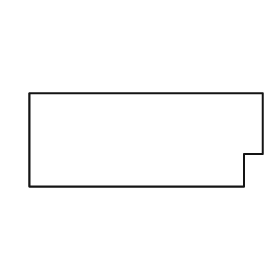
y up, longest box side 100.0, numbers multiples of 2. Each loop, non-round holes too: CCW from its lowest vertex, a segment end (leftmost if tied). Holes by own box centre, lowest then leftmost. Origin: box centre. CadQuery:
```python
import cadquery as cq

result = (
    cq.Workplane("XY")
    .moveTo(-50.0, -20.0)
    .lineTo(42.0, -20.0)
    .lineTo(42.0, -6.0)
    .lineTo(50.0, -6.0)
    .lineTo(50.0, 20.0)
    .lineTo(-50.0, 20.0)
    .close()
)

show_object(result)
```